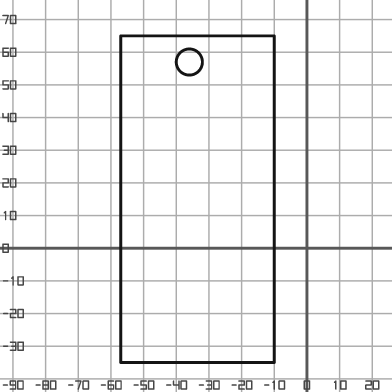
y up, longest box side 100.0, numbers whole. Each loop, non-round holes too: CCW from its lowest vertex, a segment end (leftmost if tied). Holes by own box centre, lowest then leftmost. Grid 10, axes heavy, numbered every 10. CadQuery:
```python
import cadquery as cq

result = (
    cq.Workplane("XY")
    .moveTo(-57.0, -35.0)
    .lineTo(-10.0, -35.0)
    .lineTo(-10.0, 65.0)
    .lineTo(-57.0, 65.0)
    .close()
    .moveTo(-36.0, 57.0)
    .circle(4.0)
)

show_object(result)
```